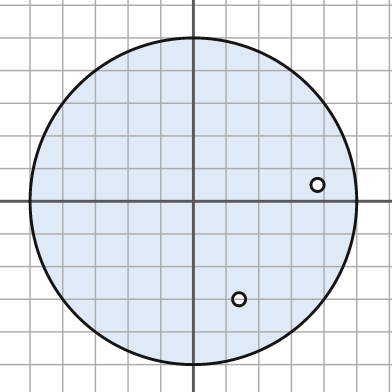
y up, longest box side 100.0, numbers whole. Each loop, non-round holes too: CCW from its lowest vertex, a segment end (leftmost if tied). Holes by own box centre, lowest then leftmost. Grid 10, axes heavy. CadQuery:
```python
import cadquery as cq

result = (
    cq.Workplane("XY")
    .moveTo(0.0, 0.0)
    .circle(50.0)
    .moveTo(14.0, -30.0)
    .circle(2.0)
    .moveTo(38.0, 5.0)
    .circle(2.0)
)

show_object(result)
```